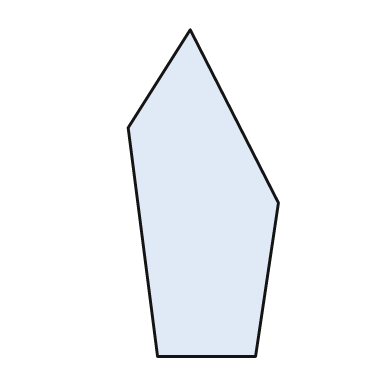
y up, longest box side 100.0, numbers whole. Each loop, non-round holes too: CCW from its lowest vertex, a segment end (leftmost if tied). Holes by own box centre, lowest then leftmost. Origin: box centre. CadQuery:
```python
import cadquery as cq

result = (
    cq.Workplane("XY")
    .moveTo(-14.0, -50.0)
    .lineTo(16.0, -50.0)
    .lineTo(23.0, -3.0)
    .lineTo(-4.0, 50.0)
    .lineTo(-23.0, 20.0)
    .close()
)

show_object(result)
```